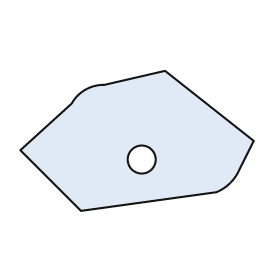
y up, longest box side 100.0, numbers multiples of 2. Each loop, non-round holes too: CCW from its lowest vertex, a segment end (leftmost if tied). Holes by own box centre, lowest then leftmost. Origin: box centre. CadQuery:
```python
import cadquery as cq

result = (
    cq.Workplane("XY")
    .moveTo(-24.0, -30.0)
    .lineTo(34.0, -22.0)
    .threePointArc((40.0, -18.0), (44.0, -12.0))
    .lineTo(50.0, 0.0)
    .lineTo(12.0, 30.0)
    .lineTo(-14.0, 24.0)
    .threePointArc((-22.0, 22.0), (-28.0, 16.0))
    .lineTo(-50.0, -4.0)
    .close()
    .moveTo(2.0, -8.0)
    .circle(6.0)
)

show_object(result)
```